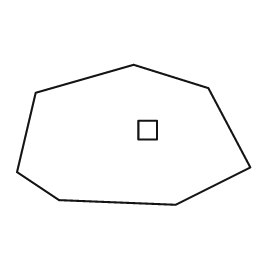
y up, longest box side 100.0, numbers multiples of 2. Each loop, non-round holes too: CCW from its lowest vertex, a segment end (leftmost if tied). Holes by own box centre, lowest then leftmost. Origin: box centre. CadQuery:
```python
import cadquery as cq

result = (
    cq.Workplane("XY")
    .moveTo(18.0, -30.0)
    .lineTo(50.0, -14.0)
    .lineTo(32.0, 20.0)
    .lineTo(0.0, 30.0)
    .lineTo(-42.0, 18.0)
    .lineTo(-50.0, -16.0)
    .lineTo(-32.0, -28.0)
    .close()
    .moveTo(2.0, -2.0)
    .lineTo(10.0, -2.0)
    .lineTo(10.0, 6.0)
    .lineTo(2.0, 6.0)
    .close()
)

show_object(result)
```